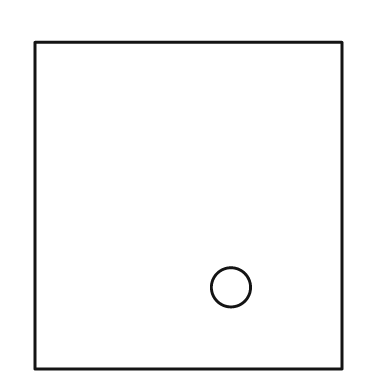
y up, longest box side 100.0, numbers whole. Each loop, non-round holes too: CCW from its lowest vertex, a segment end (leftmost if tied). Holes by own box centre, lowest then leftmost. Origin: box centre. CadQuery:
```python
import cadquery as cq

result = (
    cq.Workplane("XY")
    .moveTo(-47.0, -50.0)
    .lineTo(47.0, -50.0)
    .lineTo(47.0, 50.0)
    .lineTo(-47.0, 50.0)
    .close()
    .moveTo(13.0, -25.0)
    .circle(6.0)
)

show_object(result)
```